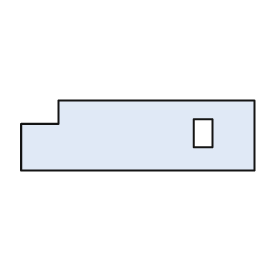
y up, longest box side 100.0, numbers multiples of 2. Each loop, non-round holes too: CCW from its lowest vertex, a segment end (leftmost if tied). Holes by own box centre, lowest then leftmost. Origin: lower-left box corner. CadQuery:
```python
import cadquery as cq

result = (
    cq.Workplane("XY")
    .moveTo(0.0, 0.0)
    .lineTo(100.0, 0.0)
    .lineTo(100.0, 30.0)
    .lineTo(16.0, 30.0)
    .lineTo(16.0, 20.0)
    .lineTo(0.0, 20.0)
    .close()
    .moveTo(74.0, 10.0)
    .lineTo(82.0, 10.0)
    .lineTo(82.0, 22.0)
    .lineTo(74.0, 22.0)
    .close()
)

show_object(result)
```